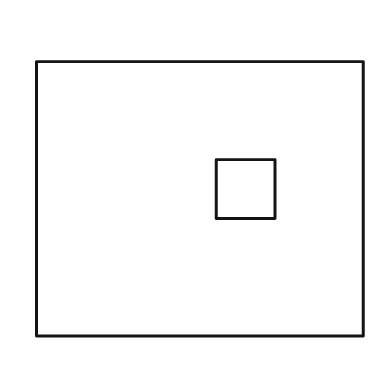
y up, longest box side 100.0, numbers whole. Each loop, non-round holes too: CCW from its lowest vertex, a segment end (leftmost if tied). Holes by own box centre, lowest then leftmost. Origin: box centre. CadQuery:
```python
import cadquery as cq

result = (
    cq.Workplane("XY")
    .moveTo(-50.0, -42.0)
    .lineTo(50.0, -42.0)
    .lineTo(50.0, 42.0)
    .lineTo(-50.0, 42.0)
    .close()
    .moveTo(5.0, -6.0)
    .lineTo(23.0, -6.0)
    .lineTo(23.0, 12.0)
    .lineTo(5.0, 12.0)
    .close()
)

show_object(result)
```